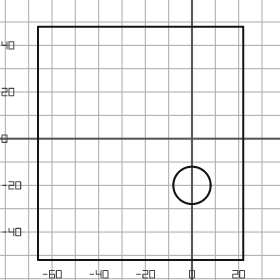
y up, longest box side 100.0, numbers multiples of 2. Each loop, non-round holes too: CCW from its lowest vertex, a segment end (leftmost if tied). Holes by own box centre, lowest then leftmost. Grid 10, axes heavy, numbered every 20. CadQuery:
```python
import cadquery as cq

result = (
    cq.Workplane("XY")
    .moveTo(-66.0, -52.0)
    .lineTo(22.0, -52.0)
    .lineTo(22.0, 48.0)
    .lineTo(-66.0, 48.0)
    .close()
    .moveTo(0.0, -20.0)
    .circle(8.0)
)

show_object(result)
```